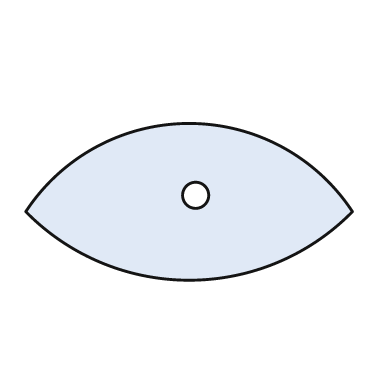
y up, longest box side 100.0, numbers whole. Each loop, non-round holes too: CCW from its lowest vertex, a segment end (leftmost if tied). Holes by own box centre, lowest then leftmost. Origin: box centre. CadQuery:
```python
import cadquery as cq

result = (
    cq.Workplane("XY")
    .moveTo(-50.0, -3.0)
    .threePointArc((0.0, -24.0), (50.0, -3.0))
    .threePointArc((0.0, 24.0), (-50.0, -3.0))
    .close()
    .moveTo(2.0, 2.0)
    .circle(4.0)
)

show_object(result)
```